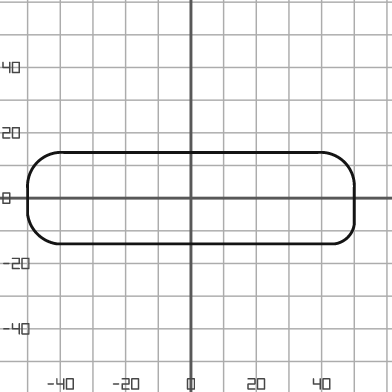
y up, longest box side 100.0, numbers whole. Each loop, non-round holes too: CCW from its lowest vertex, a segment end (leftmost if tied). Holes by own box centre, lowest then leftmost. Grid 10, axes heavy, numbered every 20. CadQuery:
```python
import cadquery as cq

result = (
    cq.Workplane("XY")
    .moveTo(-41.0, -14.0)
    .lineTo(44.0, -14.0)
    .threePointArc((48.0, -12.0), (50.0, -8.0))
    .lineTo(50.0, 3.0)
    .threePointArc((47.0, 11.0), (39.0, 14.0))
    .lineTo(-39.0, 14.0)
    .threePointArc((-47.0, 11.0), (-50.0, 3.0))
    .lineTo(-50.0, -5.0)
    .threePointArc((-47.0, -11.0), (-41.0, -14.0))
    .close()
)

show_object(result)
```